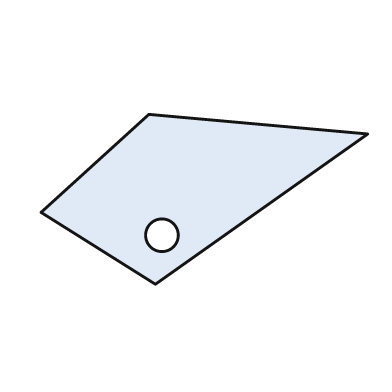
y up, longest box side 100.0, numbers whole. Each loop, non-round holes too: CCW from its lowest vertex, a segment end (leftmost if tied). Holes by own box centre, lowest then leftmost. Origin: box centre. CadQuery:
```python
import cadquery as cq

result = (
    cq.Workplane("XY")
    .moveTo(-15.0, -26.0)
    .lineTo(50.0, 20.0)
    .lineTo(-17.0, 26.0)
    .lineTo(-50.0, -4.0)
    .close()
    .moveTo(-13.0, -11.0)
    .circle(5.0)
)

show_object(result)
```